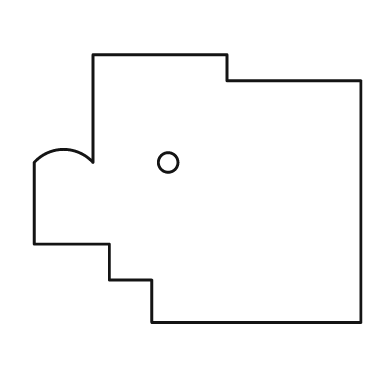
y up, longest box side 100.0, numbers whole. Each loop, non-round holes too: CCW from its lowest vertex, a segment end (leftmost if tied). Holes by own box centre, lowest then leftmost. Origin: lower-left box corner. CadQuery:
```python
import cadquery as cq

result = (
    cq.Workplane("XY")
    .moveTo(36.0, 0.0)
    .lineTo(100.0, 0.0)
    .lineTo(100.0, 74.0)
    .lineTo(59.0, 74.0)
    .lineTo(59.0, 82.0)
    .lineTo(18.0, 82.0)
    .lineTo(18.0, 49.0)
    .threePointArc((9.0, 53.0), (0.0, 49.0))
    .lineTo(0.0, 24.0)
    .lineTo(23.0, 24.0)
    .lineTo(23.0, 13.0)
    .lineTo(36.0, 13.0)
    .close()
    .moveTo(41.0, 49.0)
    .circle(3.0)
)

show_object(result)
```